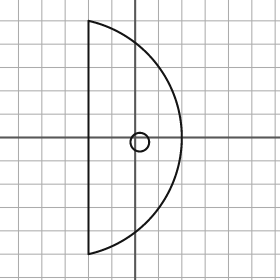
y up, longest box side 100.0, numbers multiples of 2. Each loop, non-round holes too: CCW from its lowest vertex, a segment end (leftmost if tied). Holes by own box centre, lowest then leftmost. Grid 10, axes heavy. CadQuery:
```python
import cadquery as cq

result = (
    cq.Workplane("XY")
    .moveTo(-20.0, -50.0)
    .threePointArc((20.0, 0.0), (-20.0, 50.0))
    .close()
    .moveTo(2.0, -2.0)
    .circle(4.0)
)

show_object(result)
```